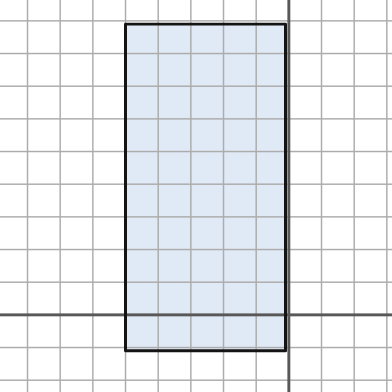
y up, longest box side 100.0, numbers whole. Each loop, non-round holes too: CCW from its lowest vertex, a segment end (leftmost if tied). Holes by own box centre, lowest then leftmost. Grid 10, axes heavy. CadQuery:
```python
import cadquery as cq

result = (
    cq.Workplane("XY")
    .moveTo(-50.0, -11.0)
    .lineTo(-1.0, -11.0)
    .lineTo(-1.0, 89.0)
    .lineTo(-50.0, 89.0)
    .close()
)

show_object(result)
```